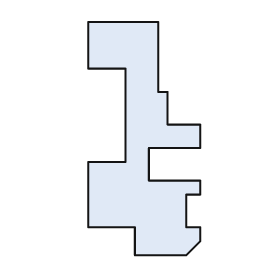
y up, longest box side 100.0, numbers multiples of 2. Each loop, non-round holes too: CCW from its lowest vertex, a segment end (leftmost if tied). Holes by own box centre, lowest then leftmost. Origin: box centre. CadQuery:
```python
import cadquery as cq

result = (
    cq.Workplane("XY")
    .moveTo(-4.0, -50.0)
    .lineTo(18.0, -50.0)
    .lineTo(24.0, -44.0)
    .lineTo(24.0, -38.0)
    .lineTo(18.0, -38.0)
    .lineTo(18.0, -24.0)
    .lineTo(24.0, -24.0)
    .lineTo(24.0, -18.0)
    .lineTo(2.0, -18.0)
    .lineTo(2.0, -4.0)
    .lineTo(24.0, -4.0)
    .lineTo(24.0, 6.0)
    .lineTo(10.0, 6.0)
    .lineTo(10.0, 20.0)
    .lineTo(6.0, 20.0)
    .lineTo(6.0, 50.0)
    .lineTo(-24.0, 50.0)
    .lineTo(-24.0, 30.0)
    .lineTo(-8.0, 30.0)
    .lineTo(-8.0, -10.0)
    .lineTo(-24.0, -10.0)
    .lineTo(-24.0, -38.0)
    .lineTo(-4.0, -38.0)
    .close()
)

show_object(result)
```